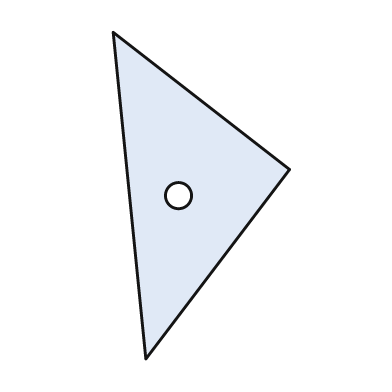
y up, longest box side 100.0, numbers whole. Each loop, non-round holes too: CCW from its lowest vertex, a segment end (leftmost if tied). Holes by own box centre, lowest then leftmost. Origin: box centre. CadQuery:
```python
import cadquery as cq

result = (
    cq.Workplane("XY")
    .moveTo(-17.0, -50.0)
    .lineTo(27.0, 8.0)
    .lineTo(-27.0, 50.0)
    .close()
    .moveTo(-7.0, 0.0)
    .circle(4.0)
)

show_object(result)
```